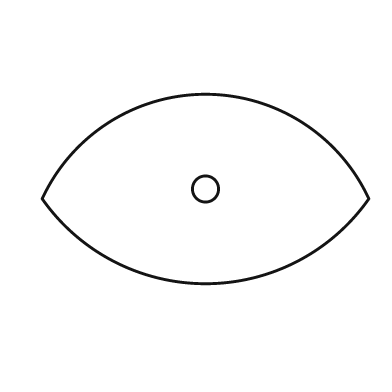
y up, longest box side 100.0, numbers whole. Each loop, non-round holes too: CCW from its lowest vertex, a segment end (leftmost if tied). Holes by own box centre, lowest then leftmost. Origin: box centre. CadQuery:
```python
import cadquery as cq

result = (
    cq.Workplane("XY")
    .moveTo(-50.0, -3.0)
    .threePointArc((0.0, -29.0), (50.0, -3.0))
    .threePointArc((0.0, 29.0), (-50.0, -3.0))
    .close()
    .moveTo(0.0, 0.0)
    .circle(4.0)
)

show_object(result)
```